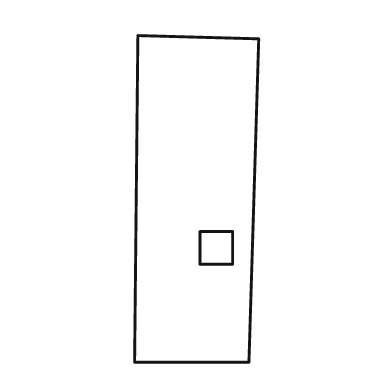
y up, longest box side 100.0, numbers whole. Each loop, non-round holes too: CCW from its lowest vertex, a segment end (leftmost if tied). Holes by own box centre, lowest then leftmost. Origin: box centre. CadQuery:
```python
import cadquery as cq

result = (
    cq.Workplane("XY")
    .moveTo(-19.0, -50.0)
    .lineTo(16.0, -50.0)
    .lineTo(19.0, 49.0)
    .lineTo(-18.0, 50.0)
    .close()
    .moveTo(1.0, -20.0)
    .lineTo(11.0, -20.0)
    .lineTo(11.0, -10.0)
    .lineTo(1.0, -10.0)
    .close()
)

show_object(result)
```